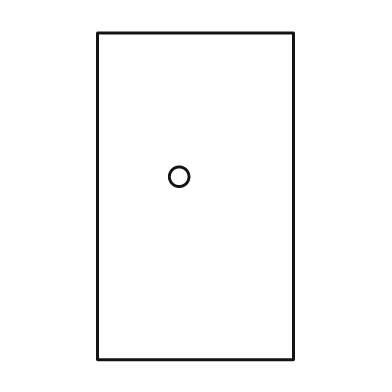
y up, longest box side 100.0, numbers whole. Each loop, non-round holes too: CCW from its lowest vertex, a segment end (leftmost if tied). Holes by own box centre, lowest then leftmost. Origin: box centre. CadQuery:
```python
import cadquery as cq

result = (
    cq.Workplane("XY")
    .moveTo(-30.0, -50.0)
    .lineTo(30.0, -50.0)
    .lineTo(30.0, 50.0)
    .lineTo(-30.0, 50.0)
    .close()
    .moveTo(-5.0, 6.0)
    .circle(3.0)
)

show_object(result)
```